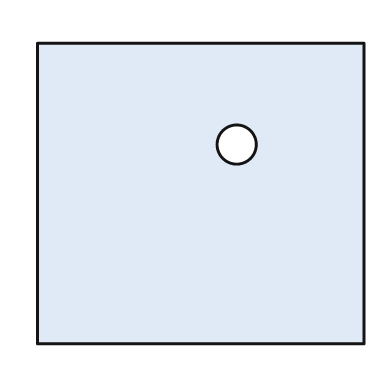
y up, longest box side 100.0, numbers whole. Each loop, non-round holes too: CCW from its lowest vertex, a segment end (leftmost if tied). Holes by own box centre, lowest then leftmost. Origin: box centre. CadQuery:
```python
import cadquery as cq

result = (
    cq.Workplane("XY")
    .moveTo(-50.0, -46.0)
    .lineTo(50.0, -46.0)
    .lineTo(50.0, 46.0)
    .lineTo(-50.0, 46.0)
    .close()
    .moveTo(11.0, 15.0)
    .circle(6.0)
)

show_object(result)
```